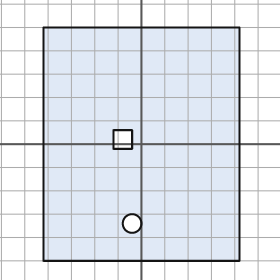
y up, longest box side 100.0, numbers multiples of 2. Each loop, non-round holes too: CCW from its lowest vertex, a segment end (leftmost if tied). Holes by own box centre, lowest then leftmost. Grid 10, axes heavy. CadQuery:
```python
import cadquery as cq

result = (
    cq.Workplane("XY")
    .moveTo(-42.0, -50.0)
    .lineTo(42.0, -50.0)
    .lineTo(42.0, 50.0)
    .lineTo(-42.0, 50.0)
    .close()
    .moveTo(-4.0, -34.0)
    .circle(4.0)
    .moveTo(-12.0, -2.0)
    .lineTo(-4.0, -2.0)
    .lineTo(-4.0, 6.0)
    .lineTo(-12.0, 6.0)
    .close()
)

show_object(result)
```